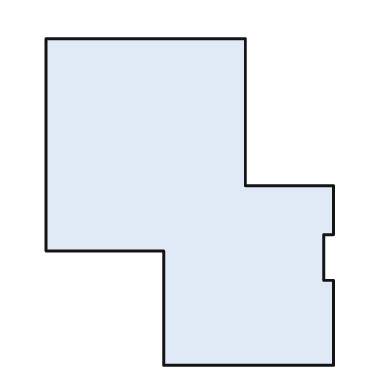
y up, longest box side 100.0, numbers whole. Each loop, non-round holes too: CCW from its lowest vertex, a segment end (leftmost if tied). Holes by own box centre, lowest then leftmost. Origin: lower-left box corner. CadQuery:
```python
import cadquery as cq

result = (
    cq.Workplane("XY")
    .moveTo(36.0, 0.0)
    .lineTo(88.0, 0.0)
    .lineTo(88.0, 26.0)
    .lineTo(85.0, 26.0)
    .lineTo(85.0, 40.0)
    .lineTo(88.0, 40.0)
    .lineTo(88.0, 55.0)
    .lineTo(61.0, 55.0)
    .lineTo(61.0, 100.0)
    .lineTo(0.0, 100.0)
    .lineTo(0.0, 35.0)
    .lineTo(36.0, 35.0)
    .close()
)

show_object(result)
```